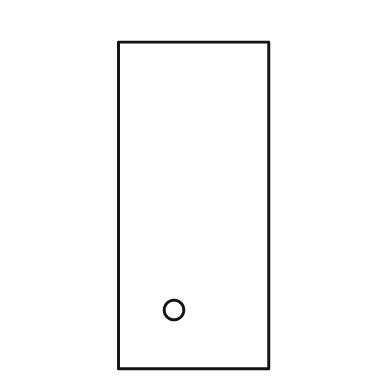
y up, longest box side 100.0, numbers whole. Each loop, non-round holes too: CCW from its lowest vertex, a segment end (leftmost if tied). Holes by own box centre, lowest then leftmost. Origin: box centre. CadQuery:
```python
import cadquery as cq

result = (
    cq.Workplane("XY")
    .moveTo(-23.0, -50.0)
    .lineTo(23.0, -50.0)
    .lineTo(23.0, 50.0)
    .lineTo(-23.0, 50.0)
    .close()
    .moveTo(-6.0, -32.0)
    .circle(3.0)
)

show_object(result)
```